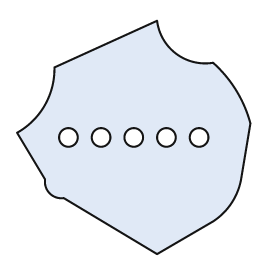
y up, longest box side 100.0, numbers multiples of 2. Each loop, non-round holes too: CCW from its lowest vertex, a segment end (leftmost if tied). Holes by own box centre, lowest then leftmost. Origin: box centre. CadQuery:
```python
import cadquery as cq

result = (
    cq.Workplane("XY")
    .moveTo(10.0, -50.0)
    .lineTo(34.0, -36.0)
    .threePointArc((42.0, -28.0), (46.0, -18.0))
    .lineTo(50.0, 6.0)
    .threePointArc((44.0, 20.0), (34.0, 32.0))
    .threePointArc((18.0, 36.0), (10.0, 50.0))
    .lineTo(-34.0, 30.0)
    .threePointArc((-38.0, 14.0), (-50.0, 2.0))
    .lineTo(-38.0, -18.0)
    .threePointArc((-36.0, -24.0), (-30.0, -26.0))
    .close()
    .moveTo(-28.0, 0.0)
    .circle(4.0)
    .moveTo(-14.0, 0.0)
    .circle(4.0)
    .moveTo(0.0, 0.0)
    .circle(4.0)
    .moveTo(14.0, 0.0)
    .circle(4.0)
    .moveTo(28.0, 0.0)
    .circle(4.0)
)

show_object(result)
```